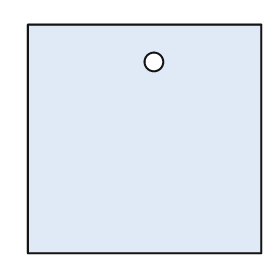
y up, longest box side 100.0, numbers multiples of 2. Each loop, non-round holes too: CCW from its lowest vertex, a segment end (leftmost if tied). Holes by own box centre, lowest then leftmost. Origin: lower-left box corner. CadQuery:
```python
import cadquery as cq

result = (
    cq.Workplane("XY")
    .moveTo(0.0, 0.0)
    .lineTo(100.0, 0.0)
    .lineTo(100.0, 98.0)
    .lineTo(0.0, 98.0)
    .close()
    .moveTo(54.0, 82.0)
    .circle(4.0)
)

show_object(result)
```